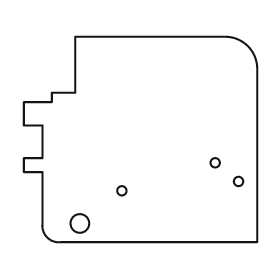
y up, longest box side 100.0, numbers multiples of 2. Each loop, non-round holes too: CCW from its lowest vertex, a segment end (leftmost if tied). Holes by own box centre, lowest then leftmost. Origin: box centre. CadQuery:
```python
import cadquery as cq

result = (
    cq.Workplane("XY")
    .moveTo(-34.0, -44.0)
    .lineTo(50.0, -44.0)
    .lineTo(50.0, 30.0)
    .threePointArc((46.0, 40.0), (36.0, 44.0))
    .lineTo(-28.0, 44.0)
    .lineTo(-28.0, 20.0)
    .lineTo(-38.0, 20.0)
    .lineTo(-38.0, 16.0)
    .lineTo(-50.0, 16.0)
    .lineTo(-50.0, 6.0)
    .lineTo(-42.0, 6.0)
    .lineTo(-42.0, -8.0)
    .lineTo(-50.0, -8.0)
    .lineTo(-50.0, -14.0)
    .lineTo(-42.0, -14.0)
    .lineTo(-42.0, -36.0)
    .threePointArc((-40.0, -42.0), (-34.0, -44.0))
    .close()
    .moveTo(-26.0, -36.0)
    .circle(4.0)
    .moveTo(-8.0, -22.0)
    .circle(2.0)
    .moveTo(42.0, -18.0)
    .circle(2.0)
    .moveTo(32.0, -10.0)
    .circle(2.0)
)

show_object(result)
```